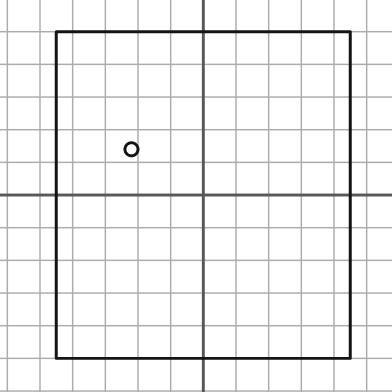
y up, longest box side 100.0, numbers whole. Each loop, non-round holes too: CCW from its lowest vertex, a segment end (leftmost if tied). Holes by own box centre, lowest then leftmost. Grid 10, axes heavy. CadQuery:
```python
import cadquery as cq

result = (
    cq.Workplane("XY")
    .moveTo(-45.0, -50.0)
    .lineTo(45.0, -50.0)
    .lineTo(45.0, 50.0)
    .lineTo(-45.0, 50.0)
    .close()
    .moveTo(-22.0, 14.0)
    .circle(2.0)
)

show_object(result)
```